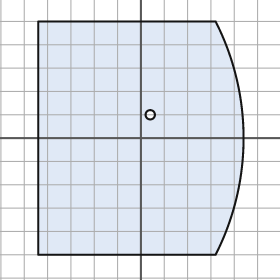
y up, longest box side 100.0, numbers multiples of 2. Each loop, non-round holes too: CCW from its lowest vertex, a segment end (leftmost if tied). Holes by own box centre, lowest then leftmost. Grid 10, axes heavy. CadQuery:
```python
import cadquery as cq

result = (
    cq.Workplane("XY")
    .moveTo(-44.0, -50.0)
    .lineTo(32.0, -50.0)
    .threePointArc((44.0, 0.0), (32.0, 50.0))
    .lineTo(-44.0, 50.0)
    .close()
    .moveTo(4.0, 10.0)
    .circle(2.0)
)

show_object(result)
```